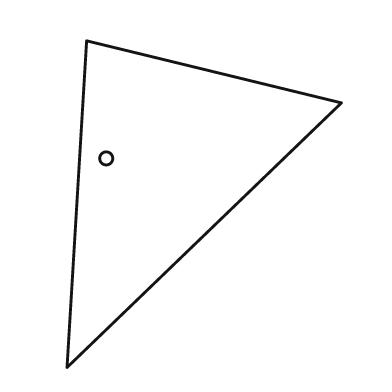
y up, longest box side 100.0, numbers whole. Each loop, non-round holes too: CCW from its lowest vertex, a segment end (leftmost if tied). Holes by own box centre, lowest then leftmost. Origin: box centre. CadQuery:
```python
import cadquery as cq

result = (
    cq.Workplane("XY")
    .moveTo(-42.0, -50.0)
    .lineTo(42.0, 31.0)
    .lineTo(-36.0, 50.0)
    .close()
    .moveTo(-30.0, 14.0)
    .circle(2.0)
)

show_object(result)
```